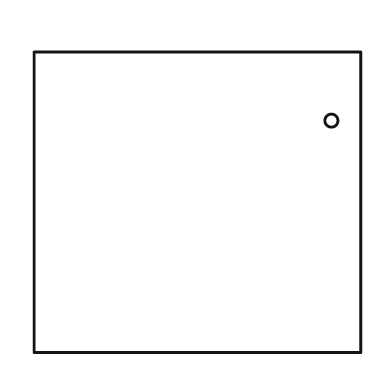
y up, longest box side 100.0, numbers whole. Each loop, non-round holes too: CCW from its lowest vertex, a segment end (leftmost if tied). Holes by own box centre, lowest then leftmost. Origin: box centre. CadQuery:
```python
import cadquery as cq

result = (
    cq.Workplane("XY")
    .moveTo(-50.0, -46.0)
    .lineTo(50.0, -46.0)
    .lineTo(50.0, 46.0)
    .lineTo(-50.0, 46.0)
    .close()
    .moveTo(41.0, 25.0)
    .circle(2.0)
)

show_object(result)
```